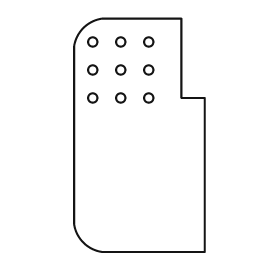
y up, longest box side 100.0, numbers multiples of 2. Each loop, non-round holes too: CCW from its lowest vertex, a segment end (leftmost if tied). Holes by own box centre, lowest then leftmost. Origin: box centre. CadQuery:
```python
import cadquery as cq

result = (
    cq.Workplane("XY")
    .moveTo(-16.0, -50.0)
    .lineTo(28.0, -50.0)
    .lineTo(28.0, 16.0)
    .lineTo(18.0, 16.0)
    .lineTo(18.0, 50.0)
    .lineTo(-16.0, 50.0)
    .threePointArc((-24.0, 46.0), (-28.0, 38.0))
    .lineTo(-28.0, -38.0)
    .threePointArc((-24.0, -46.0), (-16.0, -50.0))
    .close()
    .moveTo(-20.0, 16.0)
    .circle(2.0)
    .moveTo(-8.0, 16.0)
    .circle(2.0)
    .moveTo(4.0, 16.0)
    .circle(2.0)
    .moveTo(-20.0, 28.0)
    .circle(2.0)
    .moveTo(-8.0, 28.0)
    .circle(2.0)
    .moveTo(4.0, 28.0)
    .circle(2.0)
    .moveTo(-20.0, 40.0)
    .circle(2.0)
    .moveTo(-8.0, 40.0)
    .circle(2.0)
    .moveTo(4.0, 40.0)
    .circle(2.0)
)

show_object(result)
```